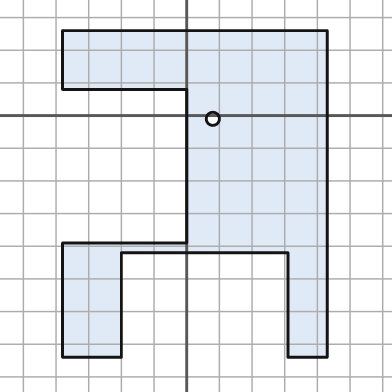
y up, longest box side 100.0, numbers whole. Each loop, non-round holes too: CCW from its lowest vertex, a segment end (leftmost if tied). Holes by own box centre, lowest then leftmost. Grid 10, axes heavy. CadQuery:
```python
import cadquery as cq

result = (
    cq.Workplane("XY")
    .moveTo(-38.0, -74.0)
    .lineTo(-20.0, -74.0)
    .lineTo(-20.0, -42.0)
    .lineTo(31.0, -42.0)
    .lineTo(31.0, -74.0)
    .lineTo(43.0, -74.0)
    .lineTo(43.0, 26.0)
    .lineTo(-38.0, 26.0)
    .lineTo(-38.0, 8.0)
    .lineTo(0.0, 8.0)
    .lineTo(0.0, -39.0)
    .lineTo(-38.0, -39.0)
    .close()
    .moveTo(8.0, -1.0)
    .circle(2.0)
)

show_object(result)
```